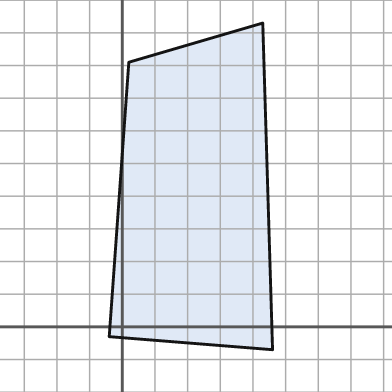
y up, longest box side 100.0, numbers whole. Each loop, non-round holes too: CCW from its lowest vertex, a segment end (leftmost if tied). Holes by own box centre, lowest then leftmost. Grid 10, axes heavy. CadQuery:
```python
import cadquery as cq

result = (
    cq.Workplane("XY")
    .moveTo(46.0, -7.0)
    .lineTo(43.0, 93.0)
    .lineTo(2.0, 81.0)
    .lineTo(-4.0, -3.0)
    .close()
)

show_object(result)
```